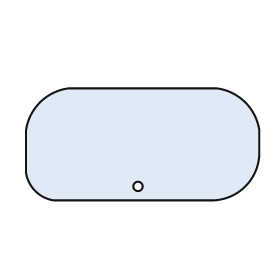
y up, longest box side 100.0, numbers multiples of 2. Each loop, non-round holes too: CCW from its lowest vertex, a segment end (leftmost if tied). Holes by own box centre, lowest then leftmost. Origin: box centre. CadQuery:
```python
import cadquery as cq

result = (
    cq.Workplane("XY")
    .moveTo(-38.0, -24.0)
    .lineTo(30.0, -24.0)
    .threePointArc((44.0, -18.0), (50.0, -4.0))
    .lineTo(50.0, 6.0)
    .threePointArc((44.0, 18.0), (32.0, 24.0))
    .lineTo(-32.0, 24.0)
    .threePointArc((-44.0, 18.0), (-50.0, 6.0))
    .lineTo(-50.0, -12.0)
    .threePointArc((-46.0, -20.0), (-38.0, -24.0))
    .close()
    .moveTo(-2.0, -18.0)
    .circle(2.0)
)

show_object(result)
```